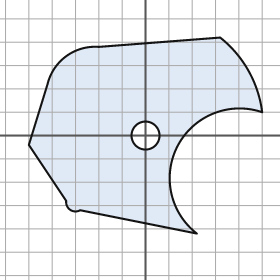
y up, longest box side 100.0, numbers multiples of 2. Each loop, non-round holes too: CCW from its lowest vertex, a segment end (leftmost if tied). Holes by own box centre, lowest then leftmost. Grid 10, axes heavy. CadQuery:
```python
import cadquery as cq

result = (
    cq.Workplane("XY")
    .moveTo(22.0, -42.0)
    .threePointArc((14.0, -4.0), (50.0, 10.0))
    .threePointArc((44.0, 28.0), (32.0, 42.0))
    .lineTo(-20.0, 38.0)
    .threePointArc((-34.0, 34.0), (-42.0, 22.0))
    .lineTo(-50.0, -4.0)
    .lineTo(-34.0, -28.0)
    .threePointArc((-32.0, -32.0), (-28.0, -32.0))
    .close()
    .moveTo(0.0, 0.0)
    .circle(6.0)
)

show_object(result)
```